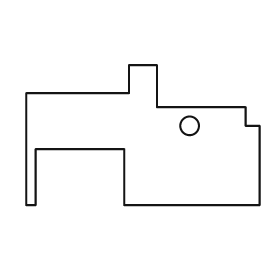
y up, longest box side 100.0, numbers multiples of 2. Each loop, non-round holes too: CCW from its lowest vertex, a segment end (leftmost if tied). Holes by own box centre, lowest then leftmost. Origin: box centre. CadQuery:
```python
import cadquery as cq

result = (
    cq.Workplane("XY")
    .moveTo(-50.0, -30.0)
    .lineTo(-46.0, -30.0)
    .lineTo(-46.0, -6.0)
    .lineTo(-8.0, -6.0)
    .lineTo(-8.0, -30.0)
    .lineTo(50.0, -30.0)
    .lineTo(50.0, 4.0)
    .lineTo(44.0, 4.0)
    .lineTo(44.0, 12.0)
    .lineTo(6.0, 12.0)
    .lineTo(6.0, 30.0)
    .lineTo(-6.0, 30.0)
    .lineTo(-6.0, 18.0)
    .lineTo(-50.0, 18.0)
    .close()
    .moveTo(20.0, 4.0)
    .circle(4.0)
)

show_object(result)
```